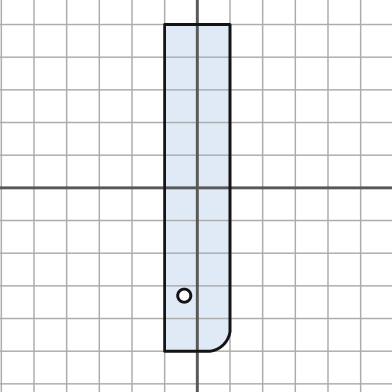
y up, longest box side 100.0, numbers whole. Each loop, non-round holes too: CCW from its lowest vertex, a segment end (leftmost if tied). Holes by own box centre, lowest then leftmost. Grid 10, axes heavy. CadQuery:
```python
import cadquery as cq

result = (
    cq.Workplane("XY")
    .moveTo(-10.0, -50.0)
    .lineTo(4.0, -50.0)
    .threePointArc((8.0, -48.0), (10.0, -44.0))
    .lineTo(10.0, 50.0)
    .lineTo(-10.0, 50.0)
    .close()
    .moveTo(-4.0, -33.0)
    .circle(2.0)
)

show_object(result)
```